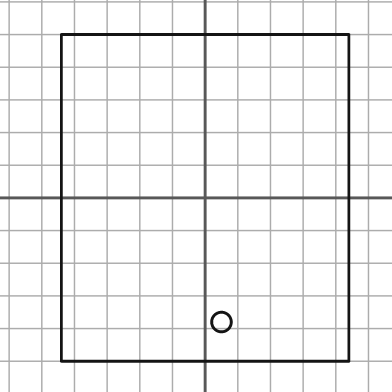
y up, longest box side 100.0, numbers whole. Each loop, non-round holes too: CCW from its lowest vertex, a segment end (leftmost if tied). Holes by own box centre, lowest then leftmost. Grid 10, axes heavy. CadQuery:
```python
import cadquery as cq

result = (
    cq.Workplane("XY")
    .moveTo(-44.0, -50.0)
    .lineTo(44.0, -50.0)
    .lineTo(44.0, 50.0)
    .lineTo(-44.0, 50.0)
    .close()
    .moveTo(5.0, -38.0)
    .circle(3.0)
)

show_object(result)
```